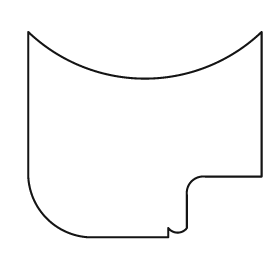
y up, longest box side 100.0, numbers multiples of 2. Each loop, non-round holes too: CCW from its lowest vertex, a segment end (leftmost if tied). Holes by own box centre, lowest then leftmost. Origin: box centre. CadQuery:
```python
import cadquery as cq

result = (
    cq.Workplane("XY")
    .moveTo(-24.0, -44.0)
    .lineTo(10.0, -44.0)
    .lineTo(10.0, -40.0)
    .threePointArc((14.0, -42.0), (18.0, -40.0))
    .lineTo(18.0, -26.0)
    .threePointArc((20.0, -20.0), (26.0, -18.0))
    .lineTo(50.0, -18.0)
    .lineTo(50.0, 44.0)
    .threePointArc((0.0, 24.0), (-50.0, 44.0))
    .lineTo(-50.0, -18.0)
    .threePointArc((-42.0, -36.0), (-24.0, -44.0))
    .close()
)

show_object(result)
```